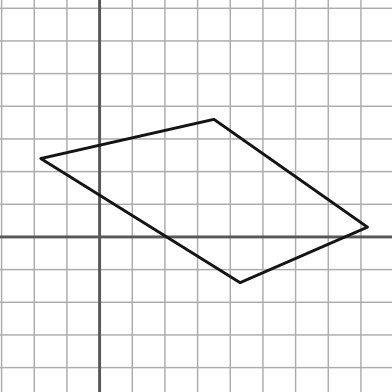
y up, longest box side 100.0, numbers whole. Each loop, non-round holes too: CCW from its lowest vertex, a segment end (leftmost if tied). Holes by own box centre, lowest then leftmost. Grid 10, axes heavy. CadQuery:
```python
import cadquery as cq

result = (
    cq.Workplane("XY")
    .moveTo(43.0, -14.0)
    .lineTo(82.0, 3.0)
    .lineTo(35.0, 36.0)
    .lineTo(-18.0, 24.0)
    .close()
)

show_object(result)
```